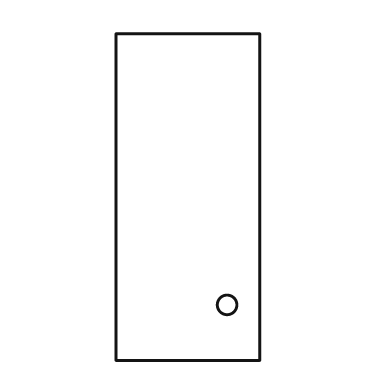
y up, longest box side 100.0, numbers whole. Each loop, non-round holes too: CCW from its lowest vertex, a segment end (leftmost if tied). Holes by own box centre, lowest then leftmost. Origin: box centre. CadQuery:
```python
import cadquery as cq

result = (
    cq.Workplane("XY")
    .moveTo(-22.0, -50.0)
    .lineTo(22.0, -50.0)
    .lineTo(22.0, 50.0)
    .lineTo(-22.0, 50.0)
    .close()
    .moveTo(12.0, -33.0)
    .circle(3.0)
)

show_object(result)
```